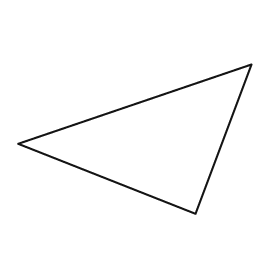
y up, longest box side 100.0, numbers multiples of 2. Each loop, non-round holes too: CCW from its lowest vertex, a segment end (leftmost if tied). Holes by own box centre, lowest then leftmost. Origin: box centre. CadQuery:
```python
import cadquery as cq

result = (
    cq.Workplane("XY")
    .moveTo(26.0, -32.0)
    .lineTo(50.0, 32.0)
    .lineTo(-50.0, -2.0)
    .close()
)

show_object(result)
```